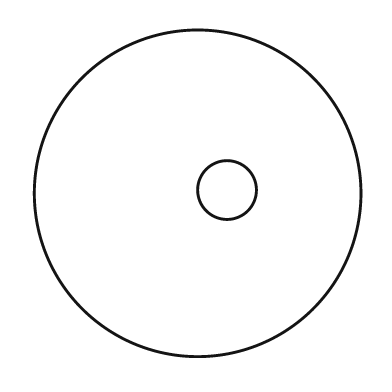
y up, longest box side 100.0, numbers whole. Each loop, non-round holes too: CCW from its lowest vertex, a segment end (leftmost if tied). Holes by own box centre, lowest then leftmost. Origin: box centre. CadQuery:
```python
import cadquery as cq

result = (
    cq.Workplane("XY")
    .moveTo(0.0, 0.0)
    .circle(50.0)
    .moveTo(9.0, 1.0)
    .circle(9.0)
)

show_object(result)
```